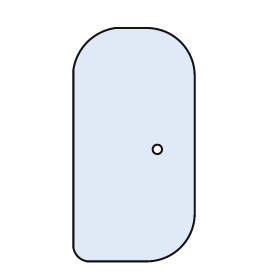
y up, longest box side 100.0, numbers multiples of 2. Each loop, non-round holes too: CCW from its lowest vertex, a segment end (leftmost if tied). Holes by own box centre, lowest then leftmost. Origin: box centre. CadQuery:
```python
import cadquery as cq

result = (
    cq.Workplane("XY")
    .moveTo(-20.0, -50.0)
    .lineTo(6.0, -50.0)
    .threePointArc((20.0, -44.0), (26.0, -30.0))
    .lineTo(26.0, 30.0)
    .threePointArc((20.0, 44.0), (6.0, 50.0))
    .lineTo(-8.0, 50.0)
    .threePointArc((-20.0, 44.0), (-26.0, 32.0))
    .lineTo(-26.0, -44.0)
    .threePointArc((-24.0, -48.0), (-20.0, -50.0))
    .close()
    .moveTo(10.0, -2.0)
    .circle(2.0)
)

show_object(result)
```